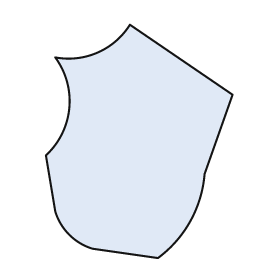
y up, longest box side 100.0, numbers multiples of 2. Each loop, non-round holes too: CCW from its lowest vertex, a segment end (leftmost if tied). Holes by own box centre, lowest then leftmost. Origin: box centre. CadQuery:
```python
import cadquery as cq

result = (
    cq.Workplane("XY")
    .moveTo(8.0, -50.0)
    .threePointArc((22.0, -34.0), (28.0, -14.0))
    .lineTo(40.0, 20.0)
    .lineTo(-4.0, 50.0)
    .threePointArc((-18.0, 38.0), (-36.0, 36.0))
    .threePointArc((-30.0, 14.0), (-40.0, -6.0))
    .lineTo(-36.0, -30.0)
    .threePointArc((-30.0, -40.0), (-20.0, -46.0))
    .close()
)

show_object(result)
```